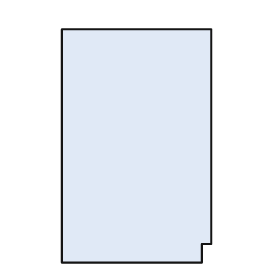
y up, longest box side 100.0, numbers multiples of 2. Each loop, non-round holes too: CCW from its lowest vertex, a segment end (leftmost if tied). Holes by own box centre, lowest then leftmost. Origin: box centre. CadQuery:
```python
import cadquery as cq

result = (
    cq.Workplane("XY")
    .moveTo(-32.0, -50.0)
    .lineTo(28.0, -50.0)
    .lineTo(28.0, -42.0)
    .lineTo(32.0, -42.0)
    .lineTo(32.0, 50.0)
    .lineTo(-32.0, 50.0)
    .close()
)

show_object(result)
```